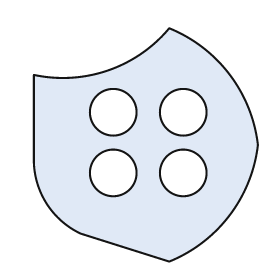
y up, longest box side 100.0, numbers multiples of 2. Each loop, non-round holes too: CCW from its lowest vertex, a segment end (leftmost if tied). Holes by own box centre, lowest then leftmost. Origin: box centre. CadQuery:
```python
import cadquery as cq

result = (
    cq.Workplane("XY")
    .moveTo(10.0, -50.0)
    .threePointArc((36.0, -30.0), (48.0, 0.0))
    .threePointArc((36.0, 30.0), (10.0, 50.0))
    .threePointArc((-16.0, 32.0), (-48.0, 30.0))
    .lineTo(-48.0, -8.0)
    .threePointArc((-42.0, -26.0), (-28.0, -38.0))
    .close()
    .moveTo(-14.0, -12.0)
    .circle(10.0)
    .moveTo(16.0, -12.0)
    .circle(10.0)
    .moveTo(-14.0, 14.0)
    .circle(10.0)
    .moveTo(16.0, 14.0)
    .circle(10.0)
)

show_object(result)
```